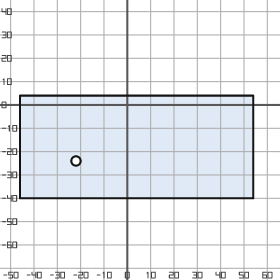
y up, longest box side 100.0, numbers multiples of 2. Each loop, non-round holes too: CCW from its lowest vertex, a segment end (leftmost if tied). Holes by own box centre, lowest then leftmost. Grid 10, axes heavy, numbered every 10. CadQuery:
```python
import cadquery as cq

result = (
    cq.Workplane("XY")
    .moveTo(-46.0, -40.0)
    .lineTo(54.0, -40.0)
    .lineTo(54.0, 4.0)
    .lineTo(-46.0, 4.0)
    .close()
    .moveTo(-22.0, -24.0)
    .circle(2.0)
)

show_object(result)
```